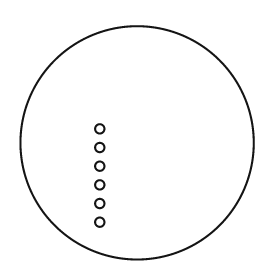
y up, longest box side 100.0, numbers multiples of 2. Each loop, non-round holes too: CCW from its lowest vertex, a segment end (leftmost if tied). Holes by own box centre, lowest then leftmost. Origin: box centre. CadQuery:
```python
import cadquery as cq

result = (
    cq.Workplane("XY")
    .moveTo(0.0, 0.0)
    .circle(50.0)
    .moveTo(-16.0, -34.0)
    .circle(2.0)
    .moveTo(-16.0, -26.0)
    .circle(2.0)
    .moveTo(-16.0, -18.0)
    .circle(2.0)
    .moveTo(-16.0, -10.0)
    .circle(2.0)
    .moveTo(-16.0, -2.0)
    .circle(2.0)
    .moveTo(-16.0, 6.0)
    .circle(2.0)
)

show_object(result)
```